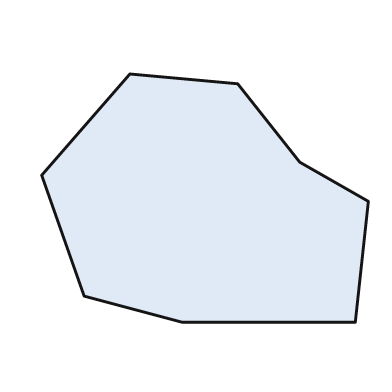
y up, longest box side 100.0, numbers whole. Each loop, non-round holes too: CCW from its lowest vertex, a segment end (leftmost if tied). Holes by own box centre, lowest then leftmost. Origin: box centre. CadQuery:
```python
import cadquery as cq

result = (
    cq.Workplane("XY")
    .moveTo(-7.0, -38.0)
    .lineTo(46.0, -38.0)
    .lineTo(50.0, -1.0)
    .lineTo(29.0, 11.0)
    .lineTo(10.0, 35.0)
    .lineTo(-23.0, 38.0)
    .lineTo(-50.0, 7.0)
    .lineTo(-37.0, -30.0)
    .close()
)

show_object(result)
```